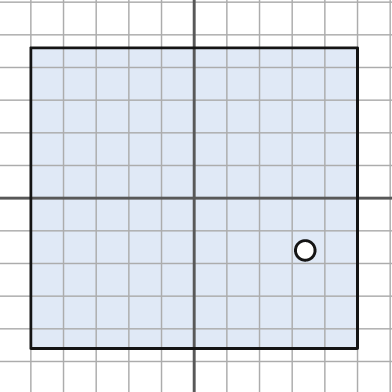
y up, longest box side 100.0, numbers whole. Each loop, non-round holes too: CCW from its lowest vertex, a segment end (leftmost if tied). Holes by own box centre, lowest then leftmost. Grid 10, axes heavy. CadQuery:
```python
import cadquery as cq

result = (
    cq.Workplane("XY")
    .moveTo(-50.0, -46.0)
    .lineTo(50.0, -46.0)
    .lineTo(50.0, 46.0)
    .lineTo(-50.0, 46.0)
    .close()
    .moveTo(34.0, -16.0)
    .circle(3.0)
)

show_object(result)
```